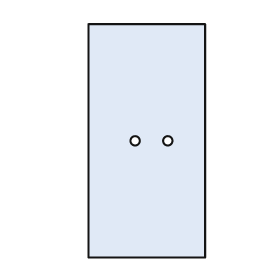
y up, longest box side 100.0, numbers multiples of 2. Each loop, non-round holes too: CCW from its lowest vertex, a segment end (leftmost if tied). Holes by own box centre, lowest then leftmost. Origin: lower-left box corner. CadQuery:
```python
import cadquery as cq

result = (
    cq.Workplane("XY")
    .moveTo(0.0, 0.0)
    .lineTo(50.0, 0.0)
    .lineTo(50.0, 100.0)
    .lineTo(0.0, 100.0)
    .close()
    .moveTo(20.0, 50.0)
    .circle(2.0)
    .moveTo(34.0, 50.0)
    .circle(2.0)
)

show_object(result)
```